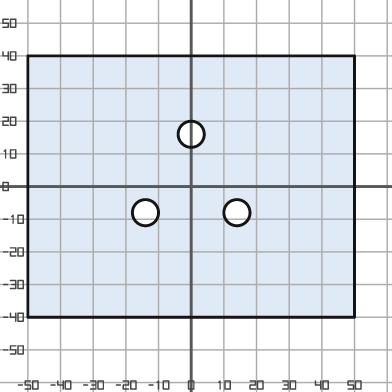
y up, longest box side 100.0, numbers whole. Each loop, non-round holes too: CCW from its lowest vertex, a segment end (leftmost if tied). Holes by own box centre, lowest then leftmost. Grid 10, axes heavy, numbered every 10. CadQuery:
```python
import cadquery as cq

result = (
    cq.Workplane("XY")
    .moveTo(-50.0, -40.0)
    .lineTo(50.0, -40.0)
    .lineTo(50.0, 40.0)
    .lineTo(-50.0, 40.0)
    .close()
    .moveTo(-14.0, -8.0)
    .circle(4.0)
    .moveTo(14.0, -8.0)
    .circle(4.0)
    .moveTo(0.0, 16.0)
    .circle(4.0)
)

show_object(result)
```